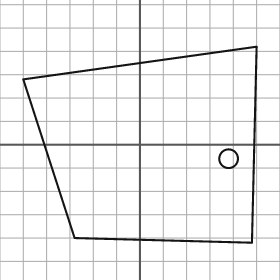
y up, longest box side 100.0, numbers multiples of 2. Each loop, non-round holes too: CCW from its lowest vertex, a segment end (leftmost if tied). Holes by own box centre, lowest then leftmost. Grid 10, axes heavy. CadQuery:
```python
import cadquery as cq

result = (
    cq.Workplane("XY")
    .moveTo(48.0, -42.0)
    .lineTo(50.0, 42.0)
    .lineTo(-50.0, 28.0)
    .lineTo(-28.0, -40.0)
    .close()
    .moveTo(38.0, -6.0)
    .circle(4.0)
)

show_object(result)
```